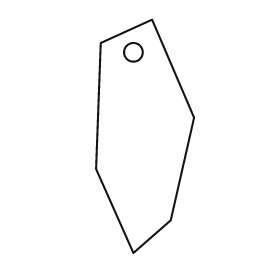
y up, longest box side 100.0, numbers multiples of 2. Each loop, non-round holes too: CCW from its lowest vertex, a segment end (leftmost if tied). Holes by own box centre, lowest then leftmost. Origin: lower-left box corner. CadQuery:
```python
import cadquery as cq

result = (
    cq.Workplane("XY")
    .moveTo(16.0, 0.0)
    .lineTo(32.0, 14.0)
    .lineTo(42.0, 58.0)
    .lineTo(24.0, 100.0)
    .lineTo(2.0, 90.0)
    .lineTo(0.0, 36.0)
    .close()
    .moveTo(16.0, 86.0)
    .circle(4.0)
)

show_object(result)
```